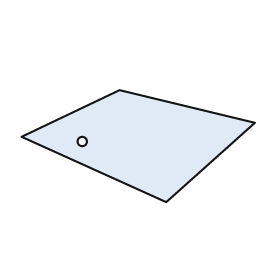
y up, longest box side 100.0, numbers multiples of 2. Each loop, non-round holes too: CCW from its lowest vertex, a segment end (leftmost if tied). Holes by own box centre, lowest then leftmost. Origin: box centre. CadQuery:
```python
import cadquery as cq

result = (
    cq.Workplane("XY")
    .moveTo(12.0, -24.0)
    .lineTo(50.0, 10.0)
    .lineTo(-8.0, 24.0)
    .lineTo(-50.0, 4.0)
    .close()
    .moveTo(-24.0, 2.0)
    .circle(2.0)
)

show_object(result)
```